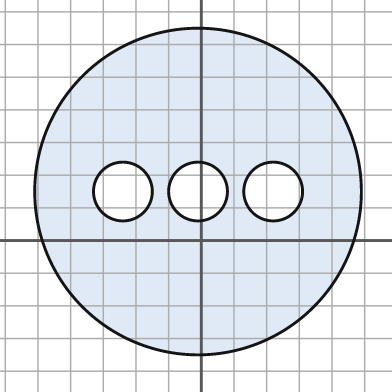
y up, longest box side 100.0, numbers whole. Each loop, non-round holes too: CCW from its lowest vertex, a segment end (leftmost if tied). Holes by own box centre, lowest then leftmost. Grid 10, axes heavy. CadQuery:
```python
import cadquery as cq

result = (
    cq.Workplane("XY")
    .moveTo(-1.0, 15.0)
    .circle(50.0)
    .moveTo(-24.0, 15.0)
    .circle(9.0)
    .moveTo(-1.0, 15.0)
    .circle(9.0)
    .moveTo(22.0, 15.0)
    .circle(9.0)
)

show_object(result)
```